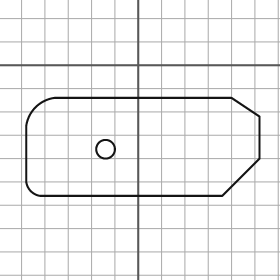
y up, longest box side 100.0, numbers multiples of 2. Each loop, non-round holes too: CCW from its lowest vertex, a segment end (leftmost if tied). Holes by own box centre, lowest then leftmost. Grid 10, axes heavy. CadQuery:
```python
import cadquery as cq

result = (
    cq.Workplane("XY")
    .moveTo(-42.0, -56.0)
    .lineTo(36.0, -56.0)
    .lineTo(52.0, -40.0)
    .lineTo(52.0, -22.0)
    .lineTo(40.0, -14.0)
    .lineTo(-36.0, -14.0)
    .threePointArc((-44.0, -18.0), (-48.0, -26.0))
    .lineTo(-48.0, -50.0)
    .threePointArc((-46.0, -54.0), (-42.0, -56.0))
    .close()
    .moveTo(-14.0, -36.0)
    .circle(4.0)
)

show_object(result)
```